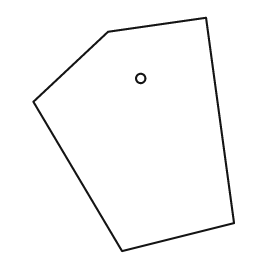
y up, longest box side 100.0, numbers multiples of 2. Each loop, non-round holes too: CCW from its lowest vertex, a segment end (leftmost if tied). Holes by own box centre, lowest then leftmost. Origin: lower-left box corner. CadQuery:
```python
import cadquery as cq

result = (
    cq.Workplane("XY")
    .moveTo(38.0, 0.0)
    .lineTo(86.0, 12.0)
    .lineTo(74.0, 100.0)
    .lineTo(32.0, 94.0)
    .lineTo(0.0, 64.0)
    .close()
    .moveTo(46.0, 74.0)
    .circle(2.0)
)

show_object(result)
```